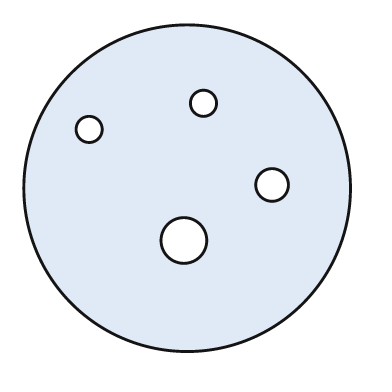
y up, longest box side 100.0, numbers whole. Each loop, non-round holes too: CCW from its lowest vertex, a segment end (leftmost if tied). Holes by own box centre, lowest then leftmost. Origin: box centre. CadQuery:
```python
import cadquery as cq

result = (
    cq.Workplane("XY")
    .moveTo(0.0, 0.0)
    .circle(50.0)
    .moveTo(-1.0, -16.0)
    .circle(7.0)
    .moveTo(26.0, 1.0)
    .circle(5.0)
    .moveTo(-30.0, 18.0)
    .circle(4.0)
    .moveTo(5.0, 26.0)
    .circle(4.0)
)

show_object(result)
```